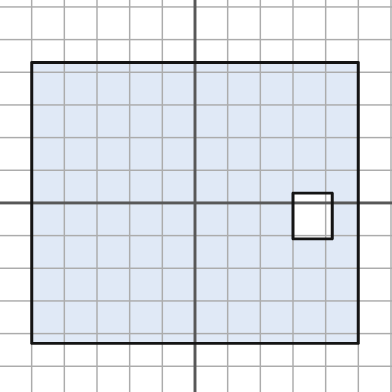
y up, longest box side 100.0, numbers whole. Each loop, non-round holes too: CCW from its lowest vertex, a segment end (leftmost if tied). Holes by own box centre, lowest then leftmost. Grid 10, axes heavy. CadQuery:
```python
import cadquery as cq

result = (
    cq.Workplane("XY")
    .moveTo(-50.0, -43.0)
    .lineTo(50.0, -43.0)
    .lineTo(50.0, 43.0)
    .lineTo(-50.0, 43.0)
    .close()
    .moveTo(30.0, -11.0)
    .lineTo(42.0, -11.0)
    .lineTo(42.0, 3.0)
    .lineTo(30.0, 3.0)
    .close()
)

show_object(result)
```